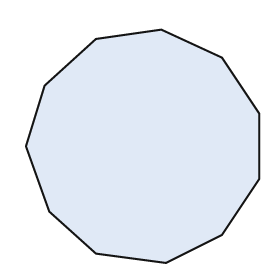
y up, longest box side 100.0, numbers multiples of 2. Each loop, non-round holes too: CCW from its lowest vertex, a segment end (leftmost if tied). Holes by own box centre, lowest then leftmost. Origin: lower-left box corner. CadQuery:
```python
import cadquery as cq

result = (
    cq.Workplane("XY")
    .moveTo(60.0, 0.0)
    .lineTo(84.0, 12.0)
    .lineTo(100.0, 36.0)
    .lineTo(100.0, 64.0)
    .lineTo(84.0, 88.0)
    .lineTo(58.0, 100.0)
    .lineTo(30.0, 96.0)
    .lineTo(8.0, 76.0)
    .lineTo(0.0, 50.0)
    .lineTo(10.0, 22.0)
    .lineTo(30.0, 4.0)
    .close()
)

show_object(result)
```